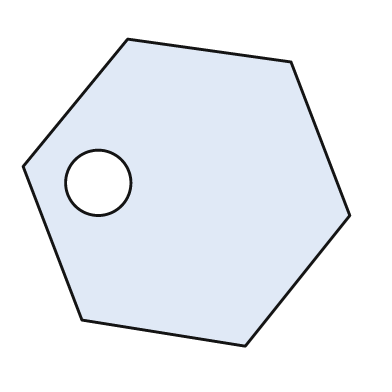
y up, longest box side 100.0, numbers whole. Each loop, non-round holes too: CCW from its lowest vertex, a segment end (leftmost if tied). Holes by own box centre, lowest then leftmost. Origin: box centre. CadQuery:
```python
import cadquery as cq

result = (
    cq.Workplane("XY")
    .moveTo(18.0, -47.0)
    .lineTo(50.0, -7.0)
    .lineTo(32.0, 40.0)
    .lineTo(-18.0, 47.0)
    .lineTo(-50.0, 8.0)
    .lineTo(-32.0, -39.0)
    .close()
    .moveTo(-27.0, 3.0)
    .circle(10.0)
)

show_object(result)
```